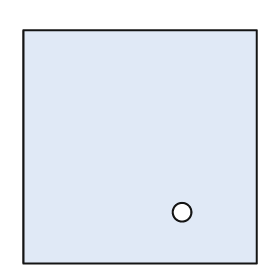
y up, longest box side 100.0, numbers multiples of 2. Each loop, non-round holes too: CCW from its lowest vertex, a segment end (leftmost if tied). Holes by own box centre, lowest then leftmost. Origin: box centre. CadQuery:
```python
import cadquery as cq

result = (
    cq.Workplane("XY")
    .moveTo(-50.0, -50.0)
    .lineTo(50.0, -50.0)
    .lineTo(50.0, 50.0)
    .lineTo(-50.0, 50.0)
    .close()
    .moveTo(18.0, -28.0)
    .circle(4.0)
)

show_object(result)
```